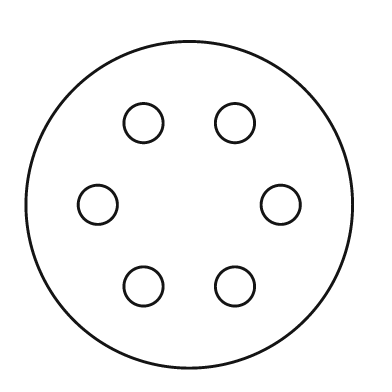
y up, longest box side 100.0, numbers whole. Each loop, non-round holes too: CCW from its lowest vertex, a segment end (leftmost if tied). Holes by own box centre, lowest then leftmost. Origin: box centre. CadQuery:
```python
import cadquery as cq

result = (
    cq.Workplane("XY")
    .moveTo(0.0, 0.0)
    .circle(50.0)
    .moveTo(-14.0, -25.0)
    .circle(6.0)
    .moveTo(14.0, -25.0)
    .circle(6.0)
    .moveTo(-28.0, 0.0)
    .circle(6.0)
    .moveTo(28.0, 0.0)
    .circle(6.0)
    .moveTo(-14.0, 25.0)
    .circle(6.0)
    .moveTo(14.0, 25.0)
    .circle(6.0)
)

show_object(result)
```